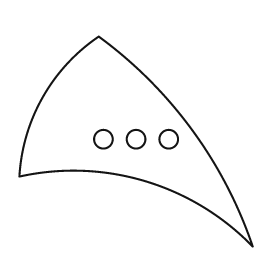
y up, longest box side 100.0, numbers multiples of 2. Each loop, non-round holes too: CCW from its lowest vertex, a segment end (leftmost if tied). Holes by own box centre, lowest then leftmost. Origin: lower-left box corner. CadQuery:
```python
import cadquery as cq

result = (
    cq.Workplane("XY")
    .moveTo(100.0, 0.0)
    .threePointArc((74.0, 50.0), (34.0, 90.0))
    .threePointArc((10.0, 64.0), (0.0, 30.0))
    .threePointArc((54.0, 28.0), (100.0, 0.0))
    .close()
    .moveTo(36.0, 46.0)
    .circle(4.0)
    .moveTo(50.0, 46.0)
    .circle(4.0)
    .moveTo(64.0, 46.0)
    .circle(4.0)
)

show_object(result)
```